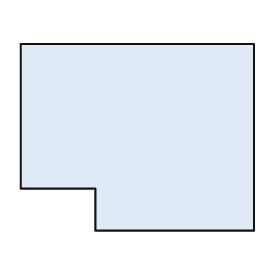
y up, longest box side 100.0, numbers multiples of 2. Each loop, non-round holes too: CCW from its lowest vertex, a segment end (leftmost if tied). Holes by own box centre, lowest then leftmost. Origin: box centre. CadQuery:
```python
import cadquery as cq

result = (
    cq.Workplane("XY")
    .moveTo(-18.0, -40.0)
    .lineTo(50.0, -40.0)
    .lineTo(50.0, 40.0)
    .lineTo(-50.0, 40.0)
    .lineTo(-50.0, -22.0)
    .lineTo(-18.0, -22.0)
    .close()
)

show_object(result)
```